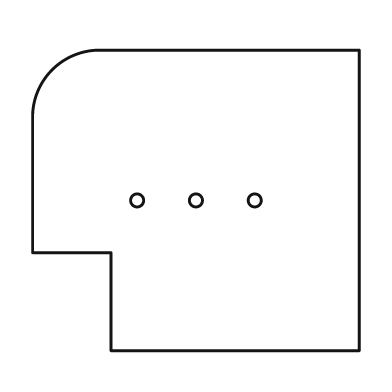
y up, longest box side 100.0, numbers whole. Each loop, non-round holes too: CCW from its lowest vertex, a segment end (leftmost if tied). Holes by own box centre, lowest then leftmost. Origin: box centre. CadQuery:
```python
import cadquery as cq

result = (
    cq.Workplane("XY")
    .moveTo(-26.0, -46.0)
    .lineTo(50.0, -46.0)
    .lineTo(50.0, 46.0)
    .lineTo(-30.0, 46.0)
    .threePointArc((-44.0, 40.0), (-50.0, 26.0))
    .lineTo(-50.0, -16.0)
    .lineTo(-26.0, -16.0)
    .close()
    .moveTo(-18.0, 0.0)
    .circle(2.0)
    .moveTo(0.0, 0.0)
    .circle(2.0)
    .moveTo(18.0, 0.0)
    .circle(2.0)
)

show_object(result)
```